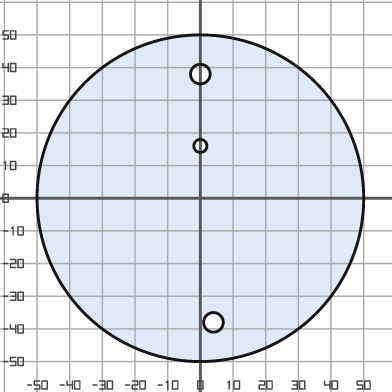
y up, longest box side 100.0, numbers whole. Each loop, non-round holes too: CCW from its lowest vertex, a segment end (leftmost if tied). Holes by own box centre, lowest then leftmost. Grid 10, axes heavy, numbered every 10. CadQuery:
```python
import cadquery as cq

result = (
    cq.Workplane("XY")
    .moveTo(0.0, 0.0)
    .circle(50.0)
    .moveTo(4.0, -38.0)
    .circle(3.0)
    .moveTo(0.0, 16.0)
    .circle(2.0)
    .moveTo(0.0, 38.0)
    .circle(3.0)
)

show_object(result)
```